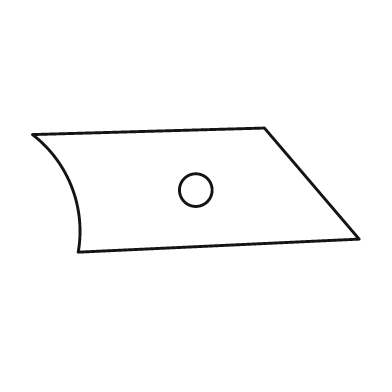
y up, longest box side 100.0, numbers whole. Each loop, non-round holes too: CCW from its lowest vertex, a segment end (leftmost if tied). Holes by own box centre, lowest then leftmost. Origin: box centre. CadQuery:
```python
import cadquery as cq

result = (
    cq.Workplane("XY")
    .moveTo(-36.0, -19.0)
    .lineTo(50.0, -15.0)
    .lineTo(21.0, 19.0)
    .lineTo(-50.0, 17.0)
    .threePointArc((-38.0, 1.0), (-36.0, -19.0))
    .close()
    .moveTo(0.0, 0.0)
    .circle(5.0)
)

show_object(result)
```